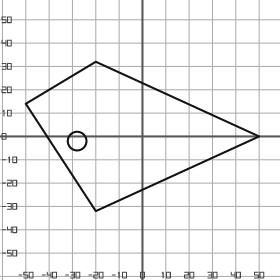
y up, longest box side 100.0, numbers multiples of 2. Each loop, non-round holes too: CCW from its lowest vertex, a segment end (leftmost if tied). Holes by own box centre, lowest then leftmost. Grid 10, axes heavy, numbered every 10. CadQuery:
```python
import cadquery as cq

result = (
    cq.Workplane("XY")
    .moveTo(-20.0, -32.0)
    .lineTo(50.0, 0.0)
    .lineTo(-20.0, 32.0)
    .lineTo(-50.0, 14.0)
    .close()
    .moveTo(-28.0, -2.0)
    .circle(4.0)
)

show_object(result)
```